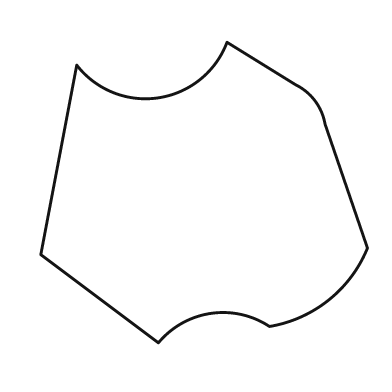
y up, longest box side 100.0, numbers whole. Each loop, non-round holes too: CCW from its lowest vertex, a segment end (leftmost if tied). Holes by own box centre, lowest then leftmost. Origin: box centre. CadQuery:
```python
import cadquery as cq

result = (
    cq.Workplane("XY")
    .moveTo(-14.0, -46.0)
    .threePointArc((2.0, -37.0), (20.0, -41.0))
    .threePointArc((38.0, -33.0), (50.0, -17.0))
    .lineTo(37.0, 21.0)
    .threePointArc((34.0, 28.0), (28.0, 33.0))
    .lineTo(7.0, 46.0)
    .threePointArc((-14.0, 29.0), (-39.0, 39.0))
    .lineTo(-50.0, -19.0)
    .close()
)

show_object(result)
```